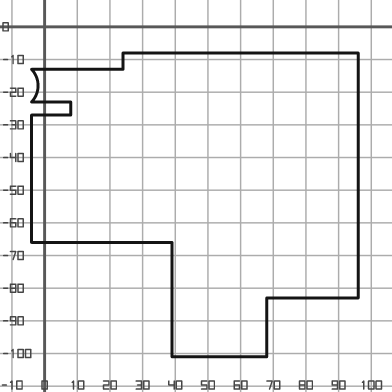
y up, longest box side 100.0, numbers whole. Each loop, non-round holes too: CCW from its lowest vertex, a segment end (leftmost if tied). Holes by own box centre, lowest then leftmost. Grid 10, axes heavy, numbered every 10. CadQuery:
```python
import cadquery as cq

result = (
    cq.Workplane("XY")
    .moveTo(39.0, -101.0)
    .lineTo(68.0, -101.0)
    .lineTo(68.0, -83.0)
    .lineTo(96.0, -83.0)
    .lineTo(96.0, -8.0)
    .lineTo(24.0, -8.0)
    .lineTo(24.0, -13.0)
    .lineTo(-4.0, -13.0)
    .threePointArc((-2.0, -18.0), (-4.0, -23.0))
    .lineTo(8.0, -23.0)
    .lineTo(8.0, -27.0)
    .lineTo(-4.0, -27.0)
    .lineTo(-4.0, -66.0)
    .lineTo(39.0, -66.0)
    .close()
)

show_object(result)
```